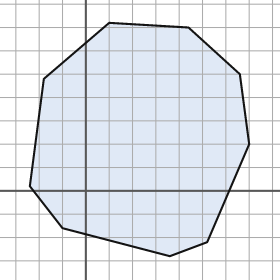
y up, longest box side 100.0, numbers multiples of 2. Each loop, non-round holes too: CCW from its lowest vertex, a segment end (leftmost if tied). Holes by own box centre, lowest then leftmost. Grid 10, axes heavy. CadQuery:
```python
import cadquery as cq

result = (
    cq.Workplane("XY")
    .moveTo(36.0, -28.0)
    .lineTo(52.0, -22.0)
    .lineTo(70.0, 20.0)
    .lineTo(66.0, 50.0)
    .lineTo(44.0, 70.0)
    .lineTo(10.0, 72.0)
    .lineTo(-18.0, 48.0)
    .lineTo(-24.0, 2.0)
    .lineTo(-10.0, -16.0)
    .close()
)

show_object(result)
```